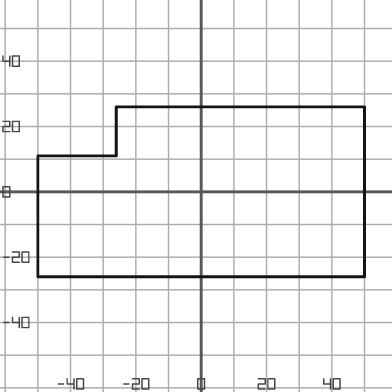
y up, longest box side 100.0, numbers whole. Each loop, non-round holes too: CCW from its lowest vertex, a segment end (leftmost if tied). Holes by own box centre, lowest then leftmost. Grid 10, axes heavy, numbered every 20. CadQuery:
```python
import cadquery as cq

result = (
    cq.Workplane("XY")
    .moveTo(-50.0, -26.0)
    .lineTo(50.0, -26.0)
    .lineTo(50.0, 26.0)
    .lineTo(-26.0, 26.0)
    .lineTo(-26.0, 11.0)
    .lineTo(-50.0, 11.0)
    .close()
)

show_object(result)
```